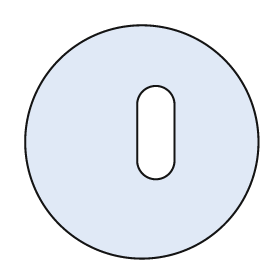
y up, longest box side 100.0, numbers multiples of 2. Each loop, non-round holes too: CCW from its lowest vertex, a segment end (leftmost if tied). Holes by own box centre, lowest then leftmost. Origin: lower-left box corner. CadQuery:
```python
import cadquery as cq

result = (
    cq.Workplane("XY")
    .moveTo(50.0, 50.0)
    .circle(50.0)
    .moveTo(48.0, 42.0)
    .threePointArc((56.0, 34.0), (64.0, 42.0))
    .lineTo(64.0, 66.0)
    .threePointArc((56.0, 74.0), (48.0, 66.0))
    .close()
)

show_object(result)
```